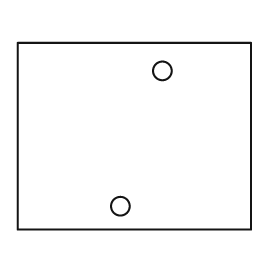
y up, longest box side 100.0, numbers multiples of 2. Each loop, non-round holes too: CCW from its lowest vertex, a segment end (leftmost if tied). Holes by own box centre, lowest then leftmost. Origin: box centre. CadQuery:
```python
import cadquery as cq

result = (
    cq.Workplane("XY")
    .moveTo(-50.0, -40.0)
    .lineTo(50.0, -40.0)
    .lineTo(50.0, 40.0)
    .lineTo(-50.0, 40.0)
    .close()
    .moveTo(-6.0, -30.0)
    .circle(4.0)
    .moveTo(12.0, 28.0)
    .circle(4.0)
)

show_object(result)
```